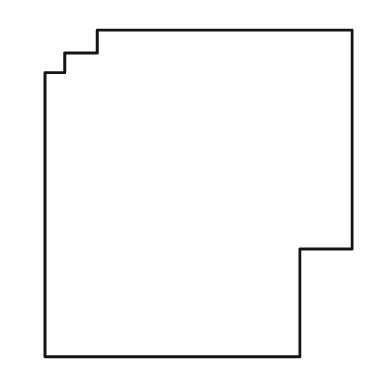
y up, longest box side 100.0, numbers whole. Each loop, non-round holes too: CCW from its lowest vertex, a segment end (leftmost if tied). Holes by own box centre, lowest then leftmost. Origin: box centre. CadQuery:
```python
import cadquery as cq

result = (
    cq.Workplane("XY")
    .moveTo(-47.0, -50.0)
    .lineTo(31.0, -50.0)
    .lineTo(31.0, -17.0)
    .lineTo(47.0, -17.0)
    .lineTo(47.0, 50.0)
    .lineTo(-31.0, 50.0)
    .lineTo(-31.0, 43.0)
    .lineTo(-41.0, 43.0)
    .lineTo(-41.0, 37.0)
    .lineTo(-47.0, 37.0)
    .close()
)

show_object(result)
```